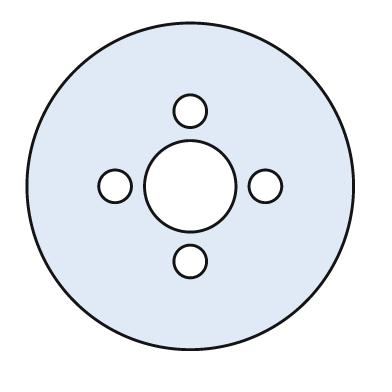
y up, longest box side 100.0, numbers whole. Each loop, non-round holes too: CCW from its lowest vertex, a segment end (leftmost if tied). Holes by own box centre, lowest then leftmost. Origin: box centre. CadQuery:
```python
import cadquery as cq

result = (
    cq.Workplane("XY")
    .moveTo(0.0, 0.0)
    .circle(50.0)
    .moveTo(0.0, -23.0)
    .circle(5.0)
    .moveTo(-23.0, 0.0)
    .circle(5.0)
    .moveTo(0.0, 0.0)
    .circle(14.0)
    .moveTo(23.0, 0.0)
    .circle(5.0)
    .moveTo(0.0, 23.0)
    .circle(5.0)
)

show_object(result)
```